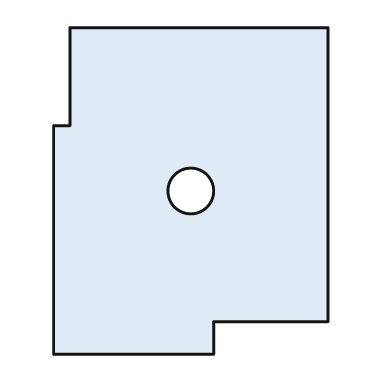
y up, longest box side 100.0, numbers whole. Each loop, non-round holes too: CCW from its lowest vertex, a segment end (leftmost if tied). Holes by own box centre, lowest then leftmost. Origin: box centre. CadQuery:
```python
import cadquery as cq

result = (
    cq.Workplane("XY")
    .moveTo(-42.0, -50.0)
    .lineTo(7.0, -50.0)
    .lineTo(7.0, -40.0)
    .lineTo(42.0, -40.0)
    .lineTo(42.0, 50.0)
    .lineTo(-37.0, 50.0)
    .lineTo(-37.0, 20.0)
    .lineTo(-42.0, 20.0)
    .close()
    .moveTo(0.0, 0.0)
    .circle(7.0)
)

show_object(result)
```